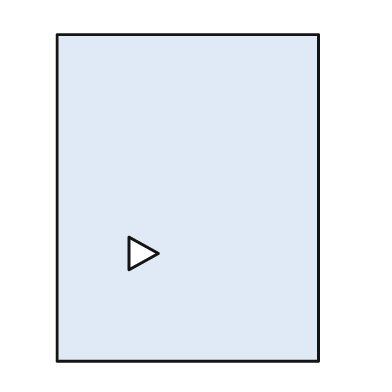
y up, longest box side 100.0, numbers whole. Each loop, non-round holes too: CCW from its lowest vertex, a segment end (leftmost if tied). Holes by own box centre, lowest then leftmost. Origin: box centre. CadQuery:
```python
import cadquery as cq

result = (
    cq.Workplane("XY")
    .moveTo(-40.0, -50.0)
    .lineTo(40.0, -50.0)
    .lineTo(40.0, 50.0)
    .lineTo(-40.0, 50.0)
    .close()
    .moveTo(-18.0, -22.0)
    .lineTo(-9.0, -17.0)
    .lineTo(-18.0, -12.0)
    .close()
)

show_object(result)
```